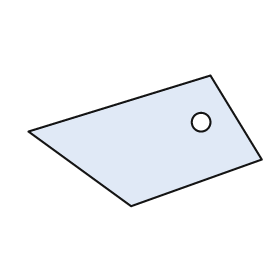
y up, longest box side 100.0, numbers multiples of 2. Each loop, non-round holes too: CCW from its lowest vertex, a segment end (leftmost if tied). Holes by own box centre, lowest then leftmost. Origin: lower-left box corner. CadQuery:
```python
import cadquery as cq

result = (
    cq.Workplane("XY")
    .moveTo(44.0, 0.0)
    .lineTo(100.0, 20.0)
    .lineTo(78.0, 56.0)
    .lineTo(0.0, 32.0)
    .close()
    .moveTo(74.0, 36.0)
    .circle(4.0)
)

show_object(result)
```